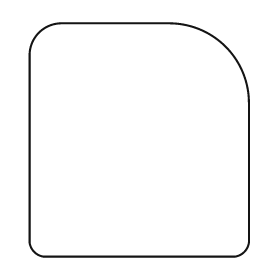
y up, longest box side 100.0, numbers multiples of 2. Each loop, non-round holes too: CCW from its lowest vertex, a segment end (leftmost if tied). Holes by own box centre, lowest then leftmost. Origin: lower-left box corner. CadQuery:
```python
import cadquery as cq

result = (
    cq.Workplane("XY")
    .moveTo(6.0, 0.0)
    .lineTo(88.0, 0.0)
    .threePointArc((92.0, 2.0), (94.0, 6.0))
    .lineTo(94.0, 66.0)
    .threePointArc((84.0, 90.0), (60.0, 100.0))
    .lineTo(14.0, 100.0)
    .threePointArc((4.0, 96.0), (0.0, 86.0))
    .lineTo(0.0, 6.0)
    .threePointArc((2.0, 2.0), (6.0, 0.0))
    .close()
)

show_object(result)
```